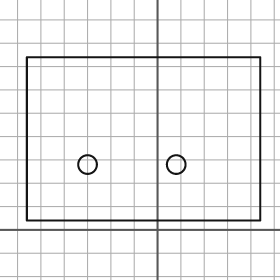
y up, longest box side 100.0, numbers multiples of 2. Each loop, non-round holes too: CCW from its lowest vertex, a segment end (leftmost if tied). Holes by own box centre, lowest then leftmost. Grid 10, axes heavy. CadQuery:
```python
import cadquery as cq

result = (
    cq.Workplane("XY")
    .moveTo(-56.0, 4.0)
    .lineTo(44.0, 4.0)
    .lineTo(44.0, 74.0)
    .lineTo(-56.0, 74.0)
    .close()
    .moveTo(-30.0, 28.0)
    .circle(4.0)
    .moveTo(8.0, 28.0)
    .circle(4.0)
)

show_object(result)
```